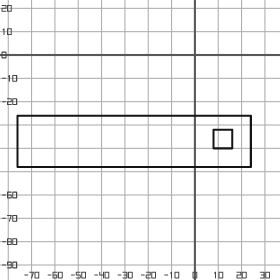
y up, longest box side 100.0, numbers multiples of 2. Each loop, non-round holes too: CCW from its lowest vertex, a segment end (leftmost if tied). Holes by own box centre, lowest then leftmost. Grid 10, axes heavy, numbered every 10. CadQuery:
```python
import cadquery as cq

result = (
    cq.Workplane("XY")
    .moveTo(-76.0, -48.0)
    .lineTo(24.0, -48.0)
    .lineTo(24.0, -26.0)
    .lineTo(-76.0, -26.0)
    .close()
    .moveTo(8.0, -40.0)
    .lineTo(16.0, -40.0)
    .lineTo(16.0, -32.0)
    .lineTo(8.0, -32.0)
    .close()
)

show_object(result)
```